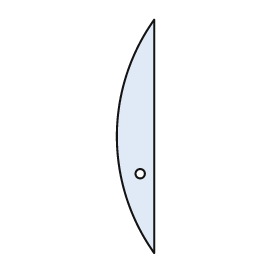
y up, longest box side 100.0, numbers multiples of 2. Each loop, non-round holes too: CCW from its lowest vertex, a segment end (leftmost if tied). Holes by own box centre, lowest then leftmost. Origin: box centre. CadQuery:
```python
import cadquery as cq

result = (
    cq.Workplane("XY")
    .moveTo(8.0, -50.0)
    .lineTo(8.0, 50.0)
    .threePointArc((-8.0, 0.0), (8.0, -50.0))
    .close()
    .moveTo(2.0, -16.0)
    .circle(2.0)
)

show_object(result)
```